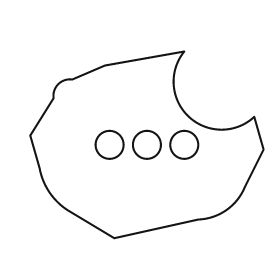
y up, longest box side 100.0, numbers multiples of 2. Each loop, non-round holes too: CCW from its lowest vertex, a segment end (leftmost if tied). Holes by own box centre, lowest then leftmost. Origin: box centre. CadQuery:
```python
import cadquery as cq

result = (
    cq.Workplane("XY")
    .moveTo(-14.0, -40.0)
    .lineTo(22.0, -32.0)
    .threePointArc((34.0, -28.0), (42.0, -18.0))
    .lineTo(50.0, -2.0)
    .lineTo(46.0, 12.0)
    .threePointArc((18.0, 12.0), (16.0, 40.0))
    .lineTo(-18.0, 34.0)
    .lineTo(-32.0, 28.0)
    .threePointArc((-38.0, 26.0), (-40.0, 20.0))
    .lineTo(-50.0, 4.0)
    .lineTo(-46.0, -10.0)
    .threePointArc((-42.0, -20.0), (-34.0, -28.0))
    .close()
    .moveTo(-16.0, 0.0)
    .circle(6.0)
    .moveTo(0.0, 0.0)
    .circle(6.0)
    .moveTo(16.0, 0.0)
    .circle(6.0)
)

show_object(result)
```